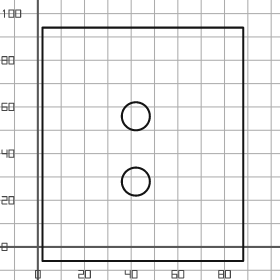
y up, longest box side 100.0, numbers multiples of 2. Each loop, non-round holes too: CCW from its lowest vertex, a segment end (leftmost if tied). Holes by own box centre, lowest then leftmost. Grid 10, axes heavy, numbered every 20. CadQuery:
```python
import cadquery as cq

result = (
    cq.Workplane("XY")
    .moveTo(2.0, -6.0)
    .lineTo(88.0, -6.0)
    .lineTo(88.0, 94.0)
    .lineTo(2.0, 94.0)
    .close()
    .moveTo(42.0, 28.0)
    .circle(6.0)
    .moveTo(42.0, 56.0)
    .circle(6.0)
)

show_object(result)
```